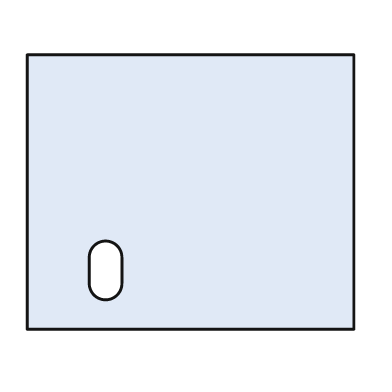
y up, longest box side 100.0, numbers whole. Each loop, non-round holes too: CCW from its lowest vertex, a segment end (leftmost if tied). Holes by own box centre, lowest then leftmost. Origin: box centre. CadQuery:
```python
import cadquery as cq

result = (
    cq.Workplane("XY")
    .moveTo(-50.0, -42.0)
    .lineTo(50.0, -42.0)
    .lineTo(50.0, 42.0)
    .lineTo(-50.0, 42.0)
    .close()
    .moveTo(-31.0, -28.0)
    .threePointArc((-26.0, -33.0), (-21.0, -28.0))
    .lineTo(-21.0, -20.0)
    .threePointArc((-26.0, -15.0), (-31.0, -20.0))
    .close()
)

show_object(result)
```